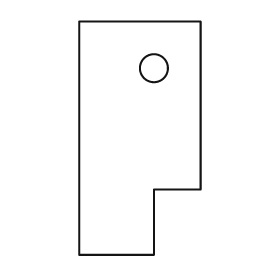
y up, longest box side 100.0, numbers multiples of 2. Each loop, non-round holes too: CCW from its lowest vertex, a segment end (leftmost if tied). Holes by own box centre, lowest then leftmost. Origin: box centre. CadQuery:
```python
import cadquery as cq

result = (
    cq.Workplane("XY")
    .moveTo(-26.0, -50.0)
    .lineTo(6.0, -50.0)
    .lineTo(6.0, -22.0)
    .lineTo(26.0, -22.0)
    .lineTo(26.0, 50.0)
    .lineTo(-26.0, 50.0)
    .close()
    .moveTo(6.0, 30.0)
    .circle(6.0)
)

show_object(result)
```